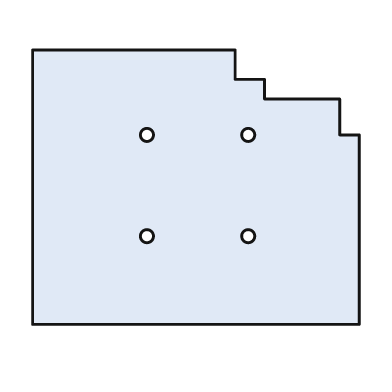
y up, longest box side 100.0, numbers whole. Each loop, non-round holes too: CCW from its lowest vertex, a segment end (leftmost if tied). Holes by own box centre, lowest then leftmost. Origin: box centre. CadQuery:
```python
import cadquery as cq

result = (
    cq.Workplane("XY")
    .moveTo(-50.0, -42.0)
    .lineTo(50.0, -42.0)
    .lineTo(50.0, 16.0)
    .lineTo(44.0, 16.0)
    .lineTo(44.0, 27.0)
    .lineTo(21.0, 27.0)
    .lineTo(21.0, 33.0)
    .lineTo(12.0, 33.0)
    .lineTo(12.0, 42.0)
    .lineTo(-50.0, 42.0)
    .close()
    .moveTo(-15.0, -15.0)
    .circle(2.0)
    .moveTo(16.0, -15.0)
    .circle(2.0)
    .moveTo(-15.0, 16.0)
    .circle(2.0)
    .moveTo(16.0, 16.0)
    .circle(2.0)
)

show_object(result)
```